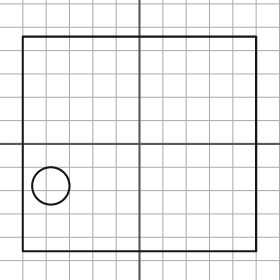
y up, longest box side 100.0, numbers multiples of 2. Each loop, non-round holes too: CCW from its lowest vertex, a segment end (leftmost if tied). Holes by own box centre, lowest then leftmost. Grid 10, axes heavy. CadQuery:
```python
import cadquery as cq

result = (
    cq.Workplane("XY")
    .moveTo(-50.0, -46.0)
    .lineTo(50.0, -46.0)
    .lineTo(50.0, 46.0)
    .lineTo(-50.0, 46.0)
    .close()
    .moveTo(-38.0, -18.0)
    .circle(8.0)
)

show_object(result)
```